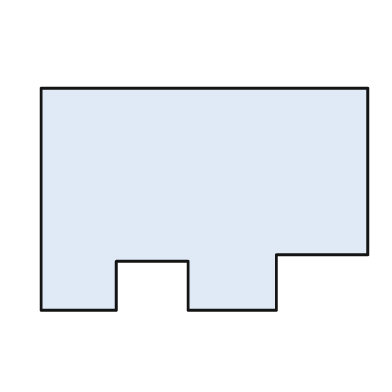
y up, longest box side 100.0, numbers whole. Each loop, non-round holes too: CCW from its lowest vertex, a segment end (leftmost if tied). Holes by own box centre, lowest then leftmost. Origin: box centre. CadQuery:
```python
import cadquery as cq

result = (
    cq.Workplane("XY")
    .moveTo(-50.0, -34.0)
    .lineTo(-27.0, -34.0)
    .lineTo(-27.0, -19.0)
    .lineTo(-5.0, -19.0)
    .lineTo(-5.0, -34.0)
    .lineTo(22.0, -34.0)
    .lineTo(22.0, -17.0)
    .lineTo(50.0, -17.0)
    .lineTo(50.0, 34.0)
    .lineTo(-50.0, 34.0)
    .close()
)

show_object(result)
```